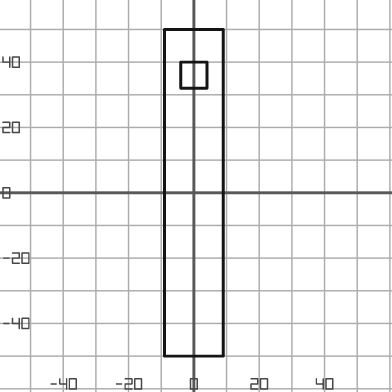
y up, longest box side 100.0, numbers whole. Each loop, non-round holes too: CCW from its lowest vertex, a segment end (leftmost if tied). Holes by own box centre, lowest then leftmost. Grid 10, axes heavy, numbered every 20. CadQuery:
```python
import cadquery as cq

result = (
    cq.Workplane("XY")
    .moveTo(-9.0, -50.0)
    .lineTo(9.0, -50.0)
    .lineTo(9.0, 50.0)
    .lineTo(-9.0, 50.0)
    .close()
    .moveTo(-4.0, 32.0)
    .lineTo(4.0, 32.0)
    .lineTo(4.0, 40.0)
    .lineTo(-4.0, 40.0)
    .close()
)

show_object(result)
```